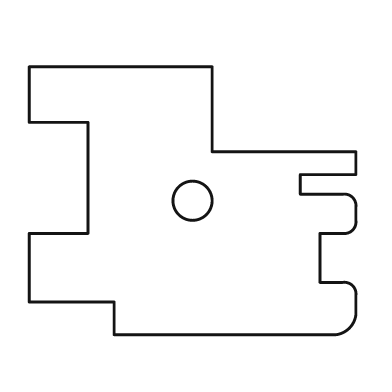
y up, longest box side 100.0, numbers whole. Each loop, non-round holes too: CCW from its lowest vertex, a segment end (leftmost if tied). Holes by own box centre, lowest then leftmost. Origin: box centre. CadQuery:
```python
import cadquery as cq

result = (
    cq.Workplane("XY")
    .moveTo(-24.0, -41.0)
    .lineTo(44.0, -41.0)
    .threePointArc((48.0, -39.0), (50.0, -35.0))
    .lineTo(50.0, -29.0)
    .threePointArc((49.0, -26.0), (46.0, -25.0))
    .lineTo(39.0, -25.0)
    .lineTo(39.0, -10.0)
    .lineTo(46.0, -10.0)
    .threePointArc((49.0, -9.0), (50.0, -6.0))
    .lineTo(50.0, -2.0)
    .threePointArc((49.0, 1.0), (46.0, 2.0))
    .lineTo(33.0, 2.0)
    .lineTo(33.0, 8.0)
    .lineTo(50.0, 8.0)
    .lineTo(50.0, 15.0)
    .lineTo(6.0, 15.0)
    .lineTo(6.0, 41.0)
    .lineTo(-50.0, 41.0)
    .lineTo(-50.0, 24.0)
    .lineTo(-32.0, 24.0)
    .lineTo(-32.0, -10.0)
    .lineTo(-50.0, -10.0)
    .lineTo(-50.0, -31.0)
    .lineTo(-24.0, -31.0)
    .close()
    .moveTo(0.0, 0.0)
    .circle(6.0)
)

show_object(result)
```